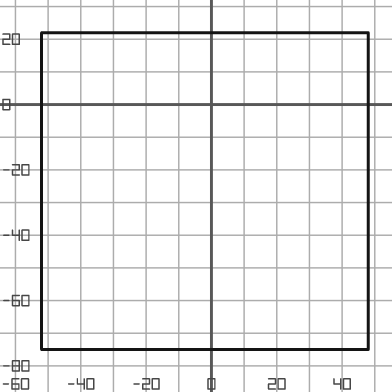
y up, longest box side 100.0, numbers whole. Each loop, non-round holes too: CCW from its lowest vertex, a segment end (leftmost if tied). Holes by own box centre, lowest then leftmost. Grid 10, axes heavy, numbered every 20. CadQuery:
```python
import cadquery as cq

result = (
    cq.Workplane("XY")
    .moveTo(-52.0, -75.0)
    .lineTo(48.0, -75.0)
    .lineTo(48.0, 22.0)
    .lineTo(-52.0, 22.0)
    .close()
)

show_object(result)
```